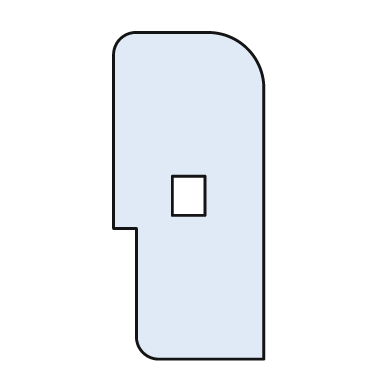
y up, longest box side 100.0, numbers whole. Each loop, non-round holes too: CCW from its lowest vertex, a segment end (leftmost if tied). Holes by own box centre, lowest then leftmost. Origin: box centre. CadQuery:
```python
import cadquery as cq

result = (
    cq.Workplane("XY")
    .moveTo(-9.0, -50.0)
    .lineTo(23.0, -50.0)
    .lineTo(23.0, 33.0)
    .threePointArc((18.0, 45.0), (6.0, 50.0))
    .lineTo(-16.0, 50.0)
    .threePointArc((-21.0, 48.0), (-23.0, 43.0))
    .lineTo(-23.0, -10.0)
    .lineTo(-16.0, -10.0)
    .lineTo(-16.0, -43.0)
    .threePointArc((-14.0, -48.0), (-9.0, -50.0))
    .close()
    .moveTo(-5.0, -6.0)
    .lineTo(5.0, -6.0)
    .lineTo(5.0, 6.0)
    .lineTo(-5.0, 6.0)
    .close()
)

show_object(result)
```